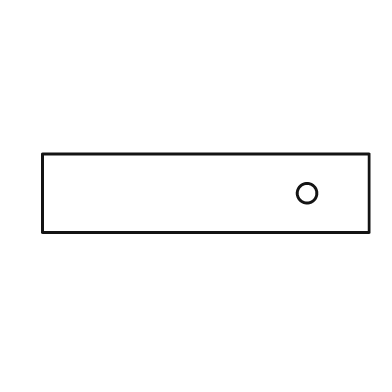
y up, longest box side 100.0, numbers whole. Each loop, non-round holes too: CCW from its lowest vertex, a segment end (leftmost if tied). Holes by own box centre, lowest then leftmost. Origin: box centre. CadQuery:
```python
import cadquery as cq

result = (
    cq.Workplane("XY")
    .moveTo(-50.0, -12.0)
    .lineTo(50.0, -12.0)
    .lineTo(50.0, 12.0)
    .lineTo(-50.0, 12.0)
    .close()
    .moveTo(31.0, 0.0)
    .circle(3.0)
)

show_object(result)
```